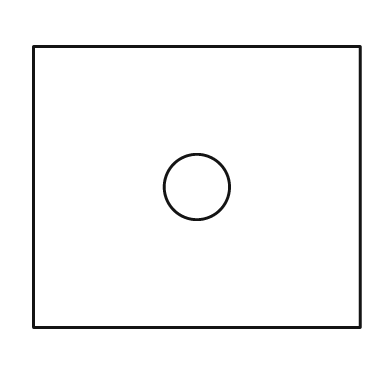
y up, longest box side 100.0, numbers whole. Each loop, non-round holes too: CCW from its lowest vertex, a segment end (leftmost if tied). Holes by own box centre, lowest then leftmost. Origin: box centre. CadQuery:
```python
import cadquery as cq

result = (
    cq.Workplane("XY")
    .moveTo(-50.0, -43.0)
    .lineTo(50.0, -43.0)
    .lineTo(50.0, 43.0)
    .lineTo(-50.0, 43.0)
    .close()
    .moveTo(0.0, 0.0)
    .circle(10.0)
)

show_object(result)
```